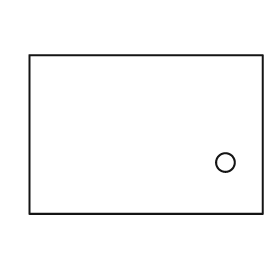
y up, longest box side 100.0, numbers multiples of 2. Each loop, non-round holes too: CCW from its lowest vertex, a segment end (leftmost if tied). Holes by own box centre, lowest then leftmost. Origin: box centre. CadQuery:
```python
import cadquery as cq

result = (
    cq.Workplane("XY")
    .moveTo(-50.0, -34.0)
    .lineTo(50.0, -34.0)
    .lineTo(50.0, 34.0)
    .lineTo(-50.0, 34.0)
    .close()
    .moveTo(34.0, -12.0)
    .circle(4.0)
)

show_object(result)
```